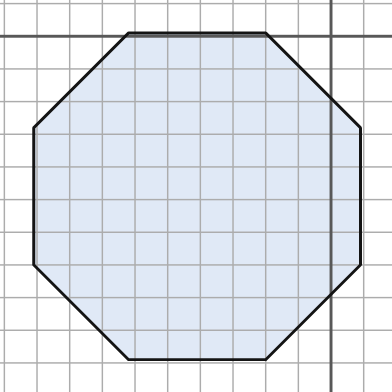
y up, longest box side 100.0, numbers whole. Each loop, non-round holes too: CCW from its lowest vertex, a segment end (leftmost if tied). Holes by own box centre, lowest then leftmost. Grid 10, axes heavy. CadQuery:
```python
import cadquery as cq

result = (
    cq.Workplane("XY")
    .moveTo(-62.0, -99.0)
    .lineTo(-20.0, -99.0)
    .lineTo(9.0, -70.0)
    .lineTo(9.0, -28.0)
    .lineTo(-20.0, 1.0)
    .lineTo(-62.0, 1.0)
    .lineTo(-91.0, -28.0)
    .lineTo(-91.0, -70.0)
    .close()
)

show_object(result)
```